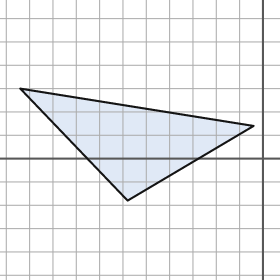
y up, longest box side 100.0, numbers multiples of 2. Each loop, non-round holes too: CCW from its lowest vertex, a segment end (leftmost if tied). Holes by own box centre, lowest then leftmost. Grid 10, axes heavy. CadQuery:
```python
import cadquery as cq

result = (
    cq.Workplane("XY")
    .moveTo(-58.0, -18.0)
    .lineTo(-4.0, 14.0)
    .lineTo(-104.0, 30.0)
    .close()
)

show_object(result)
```